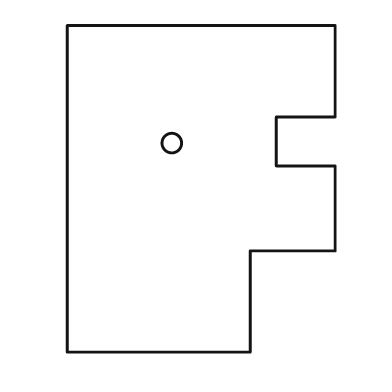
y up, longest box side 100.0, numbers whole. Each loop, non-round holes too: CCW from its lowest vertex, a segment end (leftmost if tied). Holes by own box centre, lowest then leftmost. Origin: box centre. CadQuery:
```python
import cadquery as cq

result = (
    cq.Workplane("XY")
    .moveTo(-41.0, -50.0)
    .lineTo(15.0, -50.0)
    .lineTo(15.0, -19.0)
    .lineTo(41.0, -19.0)
    .lineTo(41.0, 7.0)
    .lineTo(23.0, 7.0)
    .lineTo(23.0, 22.0)
    .lineTo(41.0, 22.0)
    .lineTo(41.0, 50.0)
    .lineTo(-41.0, 50.0)
    .close()
    .moveTo(-9.0, 14.0)
    .circle(3.0)
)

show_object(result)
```